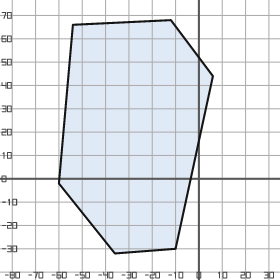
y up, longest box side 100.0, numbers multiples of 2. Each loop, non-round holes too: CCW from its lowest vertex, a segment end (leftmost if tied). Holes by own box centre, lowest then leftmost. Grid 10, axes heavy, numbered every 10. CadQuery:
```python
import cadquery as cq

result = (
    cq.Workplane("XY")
    .moveTo(-36.0, -32.0)
    .lineTo(-10.0, -30.0)
    .lineTo(6.0, 44.0)
    .lineTo(-12.0, 68.0)
    .lineTo(-54.0, 66.0)
    .lineTo(-60.0, -2.0)
    .close()
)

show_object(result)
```